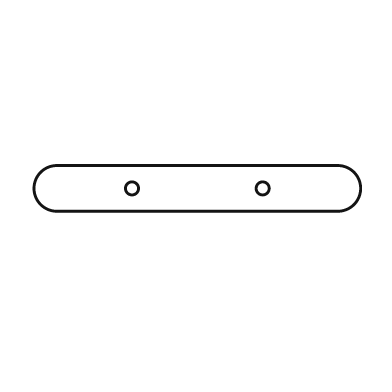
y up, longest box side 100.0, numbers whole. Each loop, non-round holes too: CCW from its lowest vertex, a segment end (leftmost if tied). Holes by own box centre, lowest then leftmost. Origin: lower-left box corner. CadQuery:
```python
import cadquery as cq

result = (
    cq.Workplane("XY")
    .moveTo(7.0, 0.0)
    .lineTo(93.0, 0.0)
    .threePointArc((100.0, 7.0), (93.0, 14.0))
    .lineTo(7.0, 14.0)
    .threePointArc((0.0, 7.0), (7.0, 0.0))
    .close()
    .moveTo(30.0, 7.0)
    .circle(2.0)
    .moveTo(70.0, 7.0)
    .circle(2.0)
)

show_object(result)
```